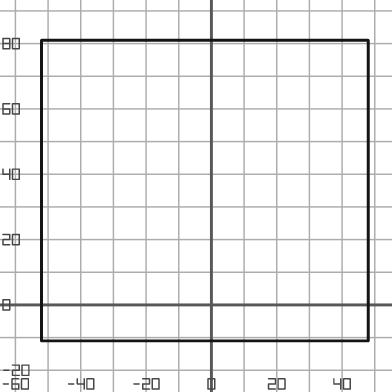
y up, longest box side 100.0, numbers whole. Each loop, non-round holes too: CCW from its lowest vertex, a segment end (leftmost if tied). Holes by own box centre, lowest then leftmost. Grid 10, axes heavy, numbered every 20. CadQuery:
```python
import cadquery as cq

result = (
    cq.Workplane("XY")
    .moveTo(-52.0, -11.0)
    .lineTo(48.0, -11.0)
    .lineTo(48.0, 81.0)
    .lineTo(-52.0, 81.0)
    .close()
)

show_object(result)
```